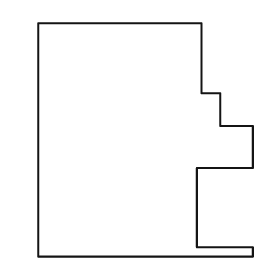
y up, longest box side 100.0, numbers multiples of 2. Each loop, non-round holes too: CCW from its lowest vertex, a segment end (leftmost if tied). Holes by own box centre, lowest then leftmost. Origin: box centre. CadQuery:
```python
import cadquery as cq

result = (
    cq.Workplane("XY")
    .moveTo(-46.0, -50.0)
    .lineTo(46.0, -50.0)
    .lineTo(46.0, -46.0)
    .lineTo(22.0, -46.0)
    .lineTo(22.0, -12.0)
    .lineTo(46.0, -12.0)
    .lineTo(46.0, 6.0)
    .lineTo(32.0, 6.0)
    .lineTo(32.0, 20.0)
    .lineTo(24.0, 20.0)
    .lineTo(24.0, 50.0)
    .lineTo(-46.0, 50.0)
    .close()
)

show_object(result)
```